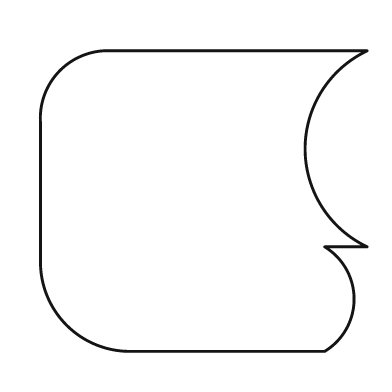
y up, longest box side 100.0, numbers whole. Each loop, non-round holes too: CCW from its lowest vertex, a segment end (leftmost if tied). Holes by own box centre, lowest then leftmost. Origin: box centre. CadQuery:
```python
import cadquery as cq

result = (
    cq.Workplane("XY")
    .moveTo(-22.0, -46.0)
    .lineTo(37.0, -46.0)
    .threePointArc((46.0, -30.0), (37.0, -14.0))
    .lineTo(50.0, -14.0)
    .threePointArc((31.0, 16.0), (50.0, 46.0))
    .lineTo(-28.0, 46.0)
    .threePointArc((-44.0, 40.0), (-50.0, 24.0))
    .lineTo(-50.0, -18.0)
    .threePointArc((-42.0, -38.0), (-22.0, -46.0))
    .close()
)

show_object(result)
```